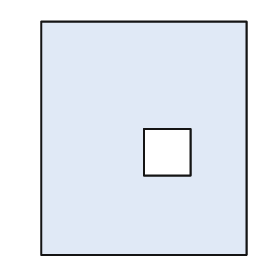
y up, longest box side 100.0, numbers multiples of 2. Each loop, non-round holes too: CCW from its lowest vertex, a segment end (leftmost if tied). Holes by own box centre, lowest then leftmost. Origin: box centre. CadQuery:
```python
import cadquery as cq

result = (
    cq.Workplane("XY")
    .moveTo(-44.0, -50.0)
    .lineTo(44.0, -50.0)
    .lineTo(44.0, 50.0)
    .lineTo(-44.0, 50.0)
    .close()
    .moveTo(0.0, -16.0)
    .lineTo(20.0, -16.0)
    .lineTo(20.0, 4.0)
    .lineTo(0.0, 4.0)
    .close()
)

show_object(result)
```